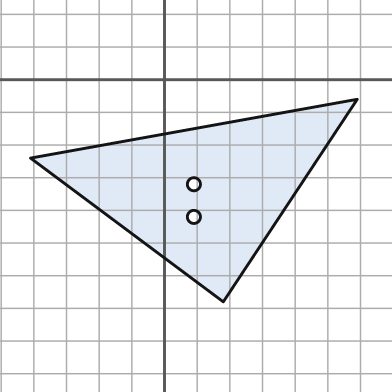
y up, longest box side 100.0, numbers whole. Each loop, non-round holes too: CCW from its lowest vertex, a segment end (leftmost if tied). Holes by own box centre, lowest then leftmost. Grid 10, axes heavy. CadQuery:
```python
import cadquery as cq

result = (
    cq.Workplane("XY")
    .moveTo(18.0, -68.0)
    .lineTo(59.0, -6.0)
    .lineTo(-41.0, -24.0)
    .close()
    .moveTo(9.0, -42.0)
    .circle(2.0)
    .moveTo(9.0, -32.0)
    .circle(2.0)
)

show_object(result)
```